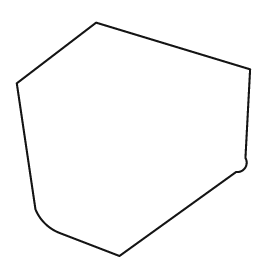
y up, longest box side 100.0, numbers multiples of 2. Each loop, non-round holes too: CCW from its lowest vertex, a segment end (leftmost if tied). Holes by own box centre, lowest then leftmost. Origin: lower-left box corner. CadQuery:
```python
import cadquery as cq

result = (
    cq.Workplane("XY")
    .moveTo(44.0, 0.0)
    .lineTo(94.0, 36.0)
    .threePointArc((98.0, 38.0), (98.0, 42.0))
    .lineTo(100.0, 80.0)
    .lineTo(34.0, 100.0)
    .lineTo(0.0, 74.0)
    .lineTo(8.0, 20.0)
    .threePointArc((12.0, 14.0), (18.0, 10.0))
    .close()
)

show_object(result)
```